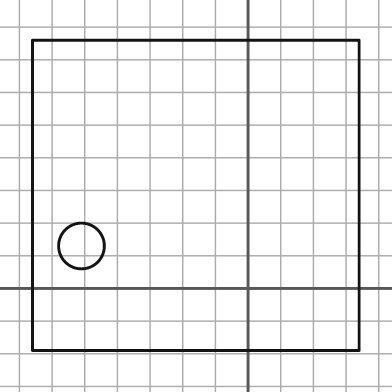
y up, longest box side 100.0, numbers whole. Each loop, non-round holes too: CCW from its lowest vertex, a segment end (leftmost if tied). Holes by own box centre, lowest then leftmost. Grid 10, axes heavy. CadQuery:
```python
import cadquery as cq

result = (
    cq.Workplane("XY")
    .moveTo(-66.0, -19.0)
    .lineTo(34.0, -19.0)
    .lineTo(34.0, 76.0)
    .lineTo(-66.0, 76.0)
    .close()
    .moveTo(-51.0, 13.0)
    .circle(7.0)
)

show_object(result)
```